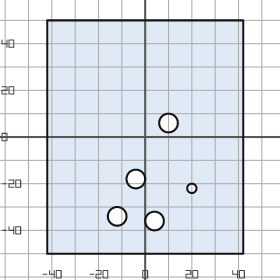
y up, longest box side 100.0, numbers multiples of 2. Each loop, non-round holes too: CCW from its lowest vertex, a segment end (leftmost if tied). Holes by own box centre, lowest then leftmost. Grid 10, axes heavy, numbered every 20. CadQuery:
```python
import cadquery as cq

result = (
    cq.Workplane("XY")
    .moveTo(-42.0, -50.0)
    .lineTo(42.0, -50.0)
    .lineTo(42.0, 50.0)
    .lineTo(-42.0, 50.0)
    .close()
    .moveTo(4.0, -36.0)
    .circle(4.0)
    .moveTo(-12.0, -34.0)
    .circle(4.0)
    .moveTo(20.0, -22.0)
    .circle(2.0)
    .moveTo(-4.0, -18.0)
    .circle(4.0)
    .moveTo(10.0, 6.0)
    .circle(4.0)
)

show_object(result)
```